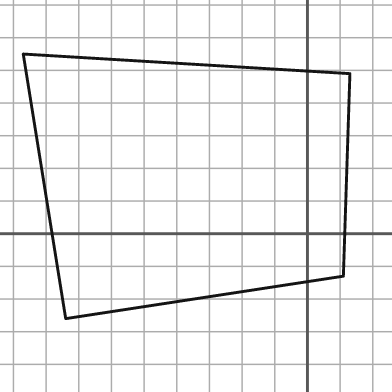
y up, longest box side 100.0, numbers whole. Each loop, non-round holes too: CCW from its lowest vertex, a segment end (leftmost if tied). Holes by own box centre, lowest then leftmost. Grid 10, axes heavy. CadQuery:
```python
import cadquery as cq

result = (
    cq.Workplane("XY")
    .moveTo(-74.0, -26.0)
    .lineTo(11.0, -13.0)
    .lineTo(13.0, 49.0)
    .lineTo(-87.0, 55.0)
    .close()
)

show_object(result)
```